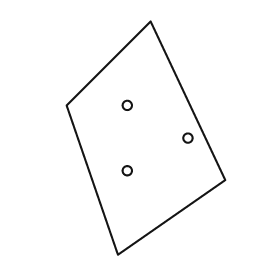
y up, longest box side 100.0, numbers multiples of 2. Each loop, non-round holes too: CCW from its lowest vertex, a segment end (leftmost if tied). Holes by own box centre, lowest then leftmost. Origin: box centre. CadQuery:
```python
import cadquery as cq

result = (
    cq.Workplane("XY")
    .moveTo(-12.0, -50.0)
    .lineTo(34.0, -18.0)
    .lineTo(2.0, 50.0)
    .lineTo(-34.0, 14.0)
    .close()
    .moveTo(-8.0, -14.0)
    .circle(2.0)
    .moveTo(18.0, 0.0)
    .circle(2.0)
    .moveTo(-8.0, 14.0)
    .circle(2.0)
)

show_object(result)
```